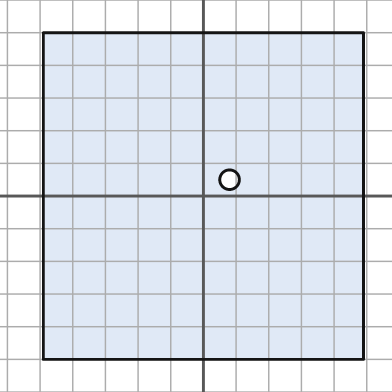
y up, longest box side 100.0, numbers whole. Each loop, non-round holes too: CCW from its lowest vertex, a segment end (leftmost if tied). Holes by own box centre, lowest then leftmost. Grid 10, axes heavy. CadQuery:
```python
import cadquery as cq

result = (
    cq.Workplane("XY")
    .moveTo(-49.0, -50.0)
    .lineTo(49.0, -50.0)
    .lineTo(49.0, 50.0)
    .lineTo(-49.0, 50.0)
    .close()
    .moveTo(8.0, 5.0)
    .circle(3.0)
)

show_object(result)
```